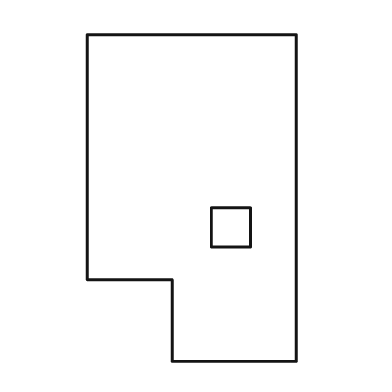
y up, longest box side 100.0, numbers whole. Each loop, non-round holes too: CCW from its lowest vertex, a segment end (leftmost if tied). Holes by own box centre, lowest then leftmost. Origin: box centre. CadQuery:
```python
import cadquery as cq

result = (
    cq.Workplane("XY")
    .moveTo(-6.0, -50.0)
    .lineTo(32.0, -50.0)
    .lineTo(32.0, 50.0)
    .lineTo(-32.0, 50.0)
    .lineTo(-32.0, -25.0)
    .lineTo(-6.0, -25.0)
    .close()
    .moveTo(6.0, -15.0)
    .lineTo(18.0, -15.0)
    .lineTo(18.0, -3.0)
    .lineTo(6.0, -3.0)
    .close()
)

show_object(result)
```